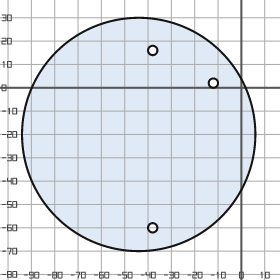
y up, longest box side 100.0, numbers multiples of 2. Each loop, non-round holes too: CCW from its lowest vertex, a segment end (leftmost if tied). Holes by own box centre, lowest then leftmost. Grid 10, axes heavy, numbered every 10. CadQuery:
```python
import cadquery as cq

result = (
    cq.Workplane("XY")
    .moveTo(-44.0, -20.0)
    .circle(50.0)
    .moveTo(-38.0, -60.0)
    .circle(2.0)
    .moveTo(-12.0, 2.0)
    .circle(2.0)
    .moveTo(-38.0, 16.0)
    .circle(2.0)
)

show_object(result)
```